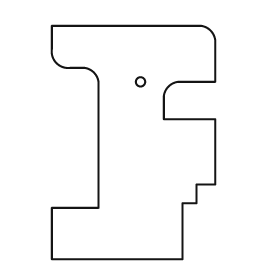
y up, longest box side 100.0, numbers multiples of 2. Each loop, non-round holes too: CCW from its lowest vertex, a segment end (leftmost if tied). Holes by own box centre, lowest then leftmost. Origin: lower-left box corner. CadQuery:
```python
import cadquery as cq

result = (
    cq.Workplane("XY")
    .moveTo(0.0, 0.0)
    .lineTo(56.0, 0.0)
    .lineTo(56.0, 24.0)
    .lineTo(62.0, 24.0)
    .lineTo(62.0, 32.0)
    .lineTo(70.0, 32.0)
    .lineTo(70.0, 60.0)
    .lineTo(48.0, 60.0)
    .lineTo(48.0, 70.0)
    .threePointArc((50.0, 74.0), (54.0, 76.0))
    .lineTo(70.0, 76.0)
    .lineTo(70.0, 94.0)
    .threePointArc((68.0, 98.0), (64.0, 100.0))
    .lineTo(0.0, 100.0)
    .lineTo(0.0, 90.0)
    .threePointArc((2.0, 84.0), (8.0, 82.0))
    .lineTo(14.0, 82.0)
    .threePointArc((18.0, 80.0), (20.0, 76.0))
    .lineTo(20.0, 22.0)
    .lineTo(0.0, 22.0)
    .close()
    .moveTo(38.0, 76.0)
    .circle(2.0)
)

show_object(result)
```